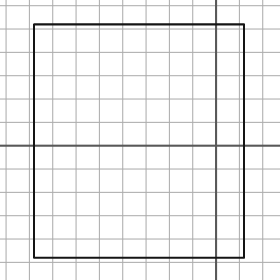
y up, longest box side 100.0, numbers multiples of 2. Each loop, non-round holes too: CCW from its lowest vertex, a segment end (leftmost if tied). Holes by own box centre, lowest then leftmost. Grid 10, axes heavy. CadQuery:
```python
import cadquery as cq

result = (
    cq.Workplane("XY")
    .moveTo(-78.0, -48.0)
    .lineTo(12.0, -48.0)
    .lineTo(12.0, 52.0)
    .lineTo(-78.0, 52.0)
    .close()
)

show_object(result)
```